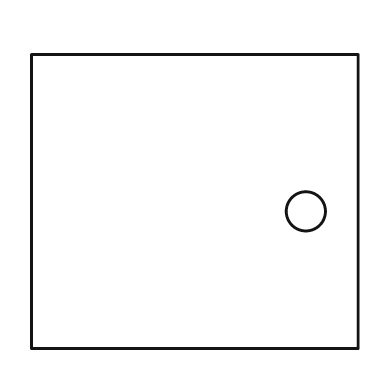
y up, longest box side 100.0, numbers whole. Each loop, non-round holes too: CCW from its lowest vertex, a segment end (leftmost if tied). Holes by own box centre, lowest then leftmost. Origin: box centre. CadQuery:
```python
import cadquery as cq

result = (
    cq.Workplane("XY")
    .moveTo(-50.0, -45.0)
    .lineTo(50.0, -45.0)
    .lineTo(50.0, 45.0)
    .lineTo(-50.0, 45.0)
    .close()
    .moveTo(34.0, -3.0)
    .circle(6.0)
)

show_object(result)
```